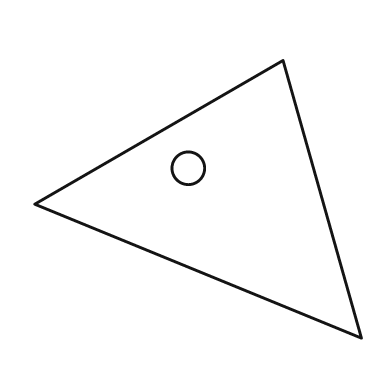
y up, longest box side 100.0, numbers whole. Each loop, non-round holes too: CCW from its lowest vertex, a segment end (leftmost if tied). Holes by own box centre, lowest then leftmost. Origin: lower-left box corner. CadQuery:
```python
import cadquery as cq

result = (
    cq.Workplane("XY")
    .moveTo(100.0, 0.0)
    .lineTo(76.0, 85.0)
    .lineTo(0.0, 41.0)
    .close()
    .moveTo(47.0, 52.0)
    .circle(5.0)
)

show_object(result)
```